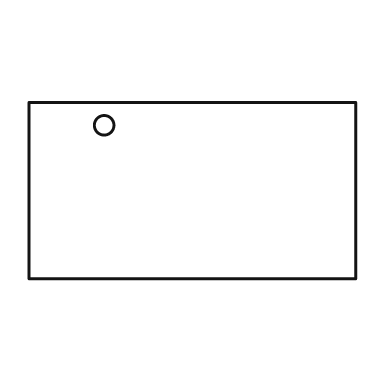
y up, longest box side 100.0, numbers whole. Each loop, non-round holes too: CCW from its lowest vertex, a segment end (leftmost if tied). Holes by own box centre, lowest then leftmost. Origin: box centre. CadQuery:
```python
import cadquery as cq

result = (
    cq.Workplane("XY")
    .moveTo(-50.0, -27.0)
    .lineTo(50.0, -27.0)
    .lineTo(50.0, 27.0)
    .lineTo(-50.0, 27.0)
    .close()
    .moveTo(-27.0, 20.0)
    .circle(3.0)
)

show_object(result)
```